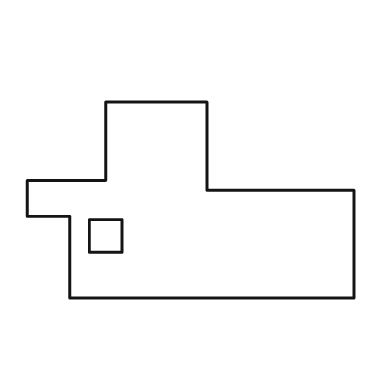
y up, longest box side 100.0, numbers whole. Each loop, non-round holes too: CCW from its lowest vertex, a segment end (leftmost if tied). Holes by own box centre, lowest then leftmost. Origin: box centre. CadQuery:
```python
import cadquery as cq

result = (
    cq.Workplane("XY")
    .moveTo(-37.0, -30.0)
    .lineTo(50.0, -30.0)
    .lineTo(50.0, 3.0)
    .lineTo(5.0, 3.0)
    .lineTo(5.0, 30.0)
    .lineTo(-26.0, 30.0)
    .lineTo(-26.0, 6.0)
    .lineTo(-50.0, 6.0)
    .lineTo(-50.0, -5.0)
    .lineTo(-37.0, -5.0)
    .close()
    .moveTo(-31.0, -16.0)
    .lineTo(-21.0, -16.0)
    .lineTo(-21.0, -6.0)
    .lineTo(-31.0, -6.0)
    .close()
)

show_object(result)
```